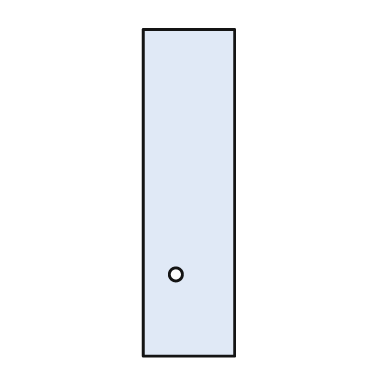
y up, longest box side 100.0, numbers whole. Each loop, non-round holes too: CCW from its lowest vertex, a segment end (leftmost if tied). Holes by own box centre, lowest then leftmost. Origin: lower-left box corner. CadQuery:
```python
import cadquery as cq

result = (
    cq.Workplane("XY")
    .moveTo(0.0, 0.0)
    .lineTo(28.0, 0.0)
    .lineTo(28.0, 100.0)
    .lineTo(0.0, 100.0)
    .close()
    .moveTo(10.0, 25.0)
    .circle(2.0)
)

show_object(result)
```